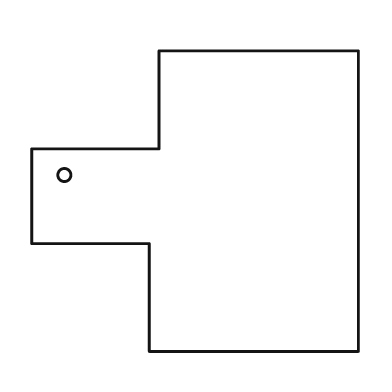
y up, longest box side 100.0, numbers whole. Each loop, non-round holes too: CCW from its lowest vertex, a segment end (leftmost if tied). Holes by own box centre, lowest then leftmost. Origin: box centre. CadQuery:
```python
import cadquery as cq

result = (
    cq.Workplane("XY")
    .moveTo(-14.0, -46.0)
    .lineTo(50.0, -46.0)
    .lineTo(50.0, 46.0)
    .lineTo(-11.0, 46.0)
    .lineTo(-11.0, 16.0)
    .lineTo(-50.0, 16.0)
    .lineTo(-50.0, -13.0)
    .lineTo(-14.0, -13.0)
    .close()
    .moveTo(-40.0, 8.0)
    .circle(2.0)
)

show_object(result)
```